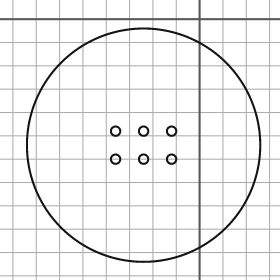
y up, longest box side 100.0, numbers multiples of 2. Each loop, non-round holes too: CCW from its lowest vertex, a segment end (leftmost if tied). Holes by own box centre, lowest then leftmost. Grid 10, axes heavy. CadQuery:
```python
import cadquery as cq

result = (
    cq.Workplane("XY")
    .moveTo(-24.0, -54.0)
    .circle(50.0)
    .moveTo(-36.0, -60.0)
    .circle(2.0)
    .moveTo(-24.0, -60.0)
    .circle(2.0)
    .moveTo(-12.0, -60.0)
    .circle(2.0)
    .moveTo(-36.0, -48.0)
    .circle(2.0)
    .moveTo(-24.0, -48.0)
    .circle(2.0)
    .moveTo(-12.0, -48.0)
    .circle(2.0)
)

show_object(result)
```